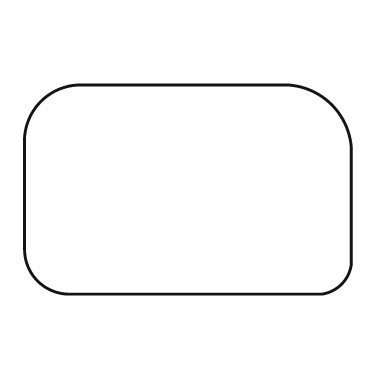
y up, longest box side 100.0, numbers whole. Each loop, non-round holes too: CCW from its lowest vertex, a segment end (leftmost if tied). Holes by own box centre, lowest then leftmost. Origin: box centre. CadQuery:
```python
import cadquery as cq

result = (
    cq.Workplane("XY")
    .moveTo(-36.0, -32.0)
    .lineTo(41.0, -32.0)
    .threePointArc((47.0, -29.0), (50.0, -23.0))
    .lineTo(50.0, 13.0)
    .threePointArc((44.0, 26.0), (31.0, 32.0))
    .lineTo(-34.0, 32.0)
    .threePointArc((-45.0, 27.0), (-50.0, 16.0))
    .lineTo(-50.0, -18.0)
    .threePointArc((-46.0, -28.0), (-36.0, -32.0))
    .close()
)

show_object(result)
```